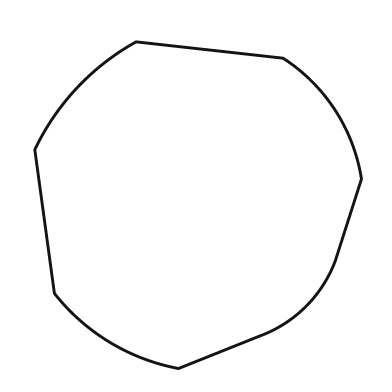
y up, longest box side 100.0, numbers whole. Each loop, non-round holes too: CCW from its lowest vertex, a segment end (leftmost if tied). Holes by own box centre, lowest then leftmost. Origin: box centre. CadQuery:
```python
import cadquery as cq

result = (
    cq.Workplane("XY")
    .moveTo(-6.0, -50.0)
    .lineTo(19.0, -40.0)
    .threePointArc((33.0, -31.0), (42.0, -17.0))
    .lineTo(50.0, 8.0)
    .threePointArc((42.0, 29.0), (26.0, 45.0))
    .lineTo(-19.0, 50.0)
    .threePointArc((-37.0, 36.0), (-50.0, 17.0))
    .lineTo(-44.0, -27.0)
    .threePointArc((-27.0, -42.0), (-6.0, -50.0))
    .close()
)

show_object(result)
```